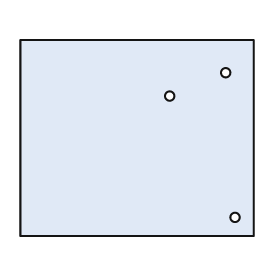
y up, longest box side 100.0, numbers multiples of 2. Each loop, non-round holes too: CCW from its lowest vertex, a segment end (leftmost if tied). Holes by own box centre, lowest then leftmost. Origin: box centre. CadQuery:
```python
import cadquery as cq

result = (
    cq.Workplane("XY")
    .moveTo(-50.0, -42.0)
    .lineTo(50.0, -42.0)
    .lineTo(50.0, 42.0)
    .lineTo(-50.0, 42.0)
    .close()
    .moveTo(42.0, -34.0)
    .circle(2.0)
    .moveTo(14.0, 18.0)
    .circle(2.0)
    .moveTo(38.0, 28.0)
    .circle(2.0)
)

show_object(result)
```